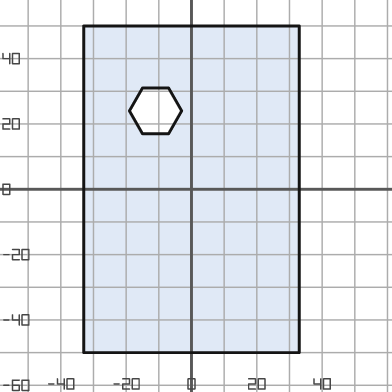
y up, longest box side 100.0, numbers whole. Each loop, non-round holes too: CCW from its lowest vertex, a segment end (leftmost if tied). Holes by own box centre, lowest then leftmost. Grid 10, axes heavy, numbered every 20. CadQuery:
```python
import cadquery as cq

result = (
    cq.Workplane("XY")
    .moveTo(-33.0, -50.0)
    .lineTo(33.0, -50.0)
    .lineTo(33.0, 50.0)
    .lineTo(-33.0, 50.0)
    .close()
    .moveTo(-15.0, 17.0)
    .lineTo(-7.0, 17.0)
    .lineTo(-3.0, 24.0)
    .lineTo(-7.0, 31.0)
    .lineTo(-15.0, 31.0)
    .lineTo(-19.0, 24.0)
    .close()
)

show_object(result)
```